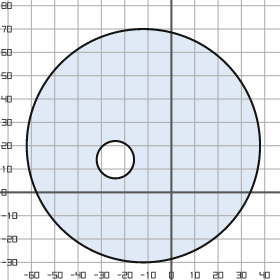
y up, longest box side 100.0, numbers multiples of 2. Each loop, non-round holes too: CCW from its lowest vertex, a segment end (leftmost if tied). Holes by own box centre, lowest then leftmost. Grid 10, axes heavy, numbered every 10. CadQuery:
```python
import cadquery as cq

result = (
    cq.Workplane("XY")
    .moveTo(-12.0, 20.0)
    .circle(50.0)
    .moveTo(-24.0, 14.0)
    .circle(8.0)
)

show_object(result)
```